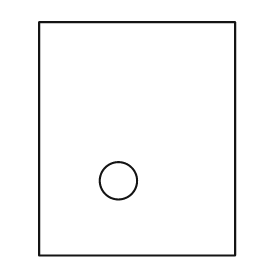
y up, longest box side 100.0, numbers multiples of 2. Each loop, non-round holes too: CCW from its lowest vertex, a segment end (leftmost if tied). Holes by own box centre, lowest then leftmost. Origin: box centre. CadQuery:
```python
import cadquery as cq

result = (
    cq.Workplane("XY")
    .moveTo(-42.0, -50.0)
    .lineTo(42.0, -50.0)
    .lineTo(42.0, 50.0)
    .lineTo(-42.0, 50.0)
    .close()
    .moveTo(-8.0, -18.0)
    .circle(8.0)
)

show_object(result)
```